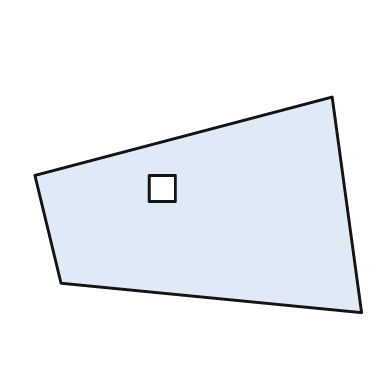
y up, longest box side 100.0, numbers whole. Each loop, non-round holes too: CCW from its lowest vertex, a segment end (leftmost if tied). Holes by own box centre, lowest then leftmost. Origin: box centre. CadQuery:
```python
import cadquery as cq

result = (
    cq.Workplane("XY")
    .moveTo(50.0, -33.0)
    .lineTo(41.0, 33.0)
    .lineTo(-50.0, 9.0)
    .lineTo(-42.0, -24.0)
    .close()
    .moveTo(-15.0, 1.0)
    .lineTo(-7.0, 1.0)
    .lineTo(-7.0, 9.0)
    .lineTo(-15.0, 9.0)
    .close()
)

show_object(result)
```